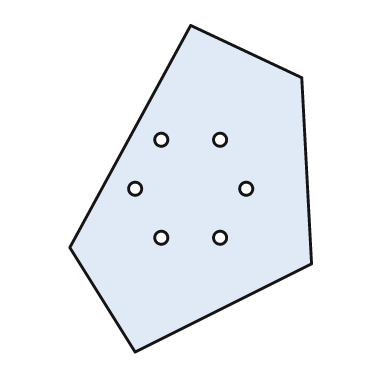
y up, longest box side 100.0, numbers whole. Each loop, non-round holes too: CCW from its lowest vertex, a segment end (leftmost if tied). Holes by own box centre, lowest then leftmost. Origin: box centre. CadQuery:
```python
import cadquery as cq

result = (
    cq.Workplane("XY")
    .moveTo(-17.0, -50.0)
    .lineTo(37.0, -23.0)
    .lineTo(34.0, 34.0)
    .lineTo(0.0, 50.0)
    .lineTo(-37.0, -18.0)
    .close()
    .moveTo(-9.0, -15.0)
    .circle(2.0)
    .moveTo(9.0, -15.0)
    .circle(2.0)
    .moveTo(-17.0, 0.0)
    .circle(2.0)
    .moveTo(17.0, 0.0)
    .circle(2.0)
    .moveTo(-9.0, 15.0)
    .circle(2.0)
    .moveTo(9.0, 15.0)
    .circle(2.0)
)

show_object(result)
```